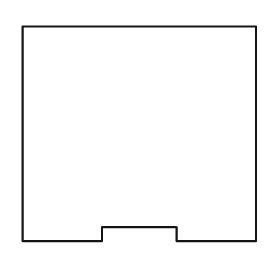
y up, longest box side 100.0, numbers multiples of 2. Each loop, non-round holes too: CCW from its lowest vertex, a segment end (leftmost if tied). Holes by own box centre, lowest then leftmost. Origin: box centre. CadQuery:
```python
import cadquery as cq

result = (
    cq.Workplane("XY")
    .moveTo(-50.0, -46.0)
    .lineTo(-16.0, -46.0)
    .lineTo(-16.0, -40.0)
    .lineTo(16.0, -40.0)
    .lineTo(16.0, -46.0)
    .lineTo(50.0, -46.0)
    .lineTo(50.0, 46.0)
    .lineTo(-50.0, 46.0)
    .close()
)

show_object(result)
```